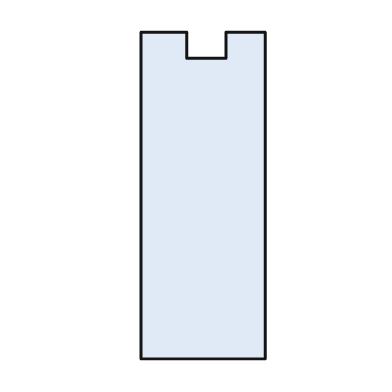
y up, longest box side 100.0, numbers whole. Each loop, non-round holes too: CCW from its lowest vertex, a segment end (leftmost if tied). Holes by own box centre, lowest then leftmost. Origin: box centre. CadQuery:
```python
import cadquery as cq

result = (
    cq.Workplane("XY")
    .moveTo(-19.0, -50.0)
    .lineTo(19.0, -50.0)
    .lineTo(19.0, 50.0)
    .lineTo(7.0, 50.0)
    .lineTo(7.0, 42.0)
    .lineTo(-5.0, 42.0)
    .lineTo(-5.0, 50.0)
    .lineTo(-19.0, 50.0)
    .close()
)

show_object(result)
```